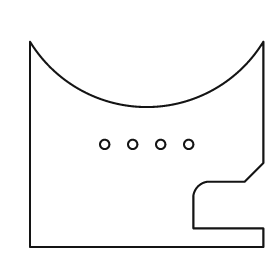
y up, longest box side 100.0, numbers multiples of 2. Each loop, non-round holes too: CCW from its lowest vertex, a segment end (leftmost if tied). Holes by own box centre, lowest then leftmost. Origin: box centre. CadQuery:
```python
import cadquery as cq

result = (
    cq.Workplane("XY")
    .moveTo(-50.0, -44.0)
    .lineTo(50.0, -44.0)
    .lineTo(50.0, -36.0)
    .lineTo(20.0, -36.0)
    .lineTo(20.0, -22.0)
    .threePointArc((22.0, -18.0), (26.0, -16.0))
    .lineTo(42.0, -16.0)
    .lineTo(50.0, -8.0)
    .lineTo(50.0, 44.0)
    .threePointArc((0.0, 16.0), (-50.0, 44.0))
    .close()
    .moveTo(-18.0, 0.0)
    .circle(2.0)
    .moveTo(-6.0, 0.0)
    .circle(2.0)
    .moveTo(6.0, 0.0)
    .circle(2.0)
    .moveTo(18.0, 0.0)
    .circle(2.0)
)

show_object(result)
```